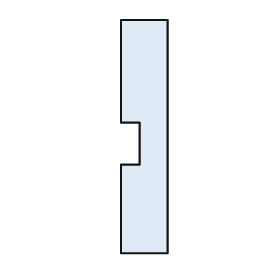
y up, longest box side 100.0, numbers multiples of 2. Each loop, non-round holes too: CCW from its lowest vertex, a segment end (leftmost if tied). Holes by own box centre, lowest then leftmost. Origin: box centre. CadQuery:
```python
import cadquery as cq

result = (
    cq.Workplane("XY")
    .moveTo(-10.0, -50.0)
    .lineTo(10.0, -50.0)
    .lineTo(10.0, 50.0)
    .lineTo(-10.0, 50.0)
    .lineTo(-10.0, 6.0)
    .lineTo(-2.0, 6.0)
    .lineTo(-2.0, -12.0)
    .lineTo(-10.0, -12.0)
    .close()
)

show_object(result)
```